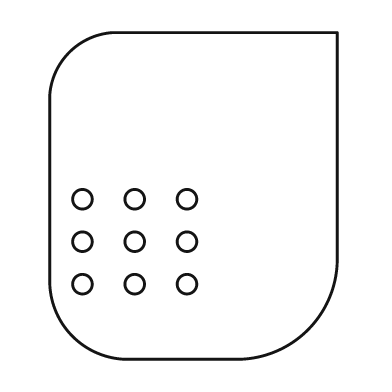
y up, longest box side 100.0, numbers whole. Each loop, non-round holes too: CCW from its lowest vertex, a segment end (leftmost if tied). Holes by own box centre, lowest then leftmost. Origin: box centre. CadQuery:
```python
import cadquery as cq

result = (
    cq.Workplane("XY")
    .moveTo(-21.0, -50.0)
    .lineTo(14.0, -50.0)
    .threePointArc((35.0, -41.0), (44.0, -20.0))
    .lineTo(44.0, 50.0)
    .lineTo(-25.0, 50.0)
    .threePointArc((-38.0, 44.0), (-44.0, 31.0))
    .lineTo(-44.0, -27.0)
    .threePointArc((-37.0, -43.0), (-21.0, -50.0))
    .close()
    .moveTo(-34.0, -27.0)
    .circle(3.0)
    .moveTo(-18.0, -27.0)
    .circle(3.0)
    .moveTo(-2.0, -27.0)
    .circle(3.0)
    .moveTo(-34.0, -14.0)
    .circle(3.0)
    .moveTo(-18.0, -14.0)
    .circle(3.0)
    .moveTo(-2.0, -14.0)
    .circle(3.0)
    .moveTo(-34.0, -1.0)
    .circle(3.0)
    .moveTo(-18.0, -1.0)
    .circle(3.0)
    .moveTo(-2.0, -1.0)
    .circle(3.0)
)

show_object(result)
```